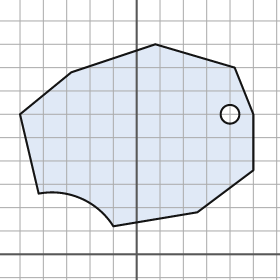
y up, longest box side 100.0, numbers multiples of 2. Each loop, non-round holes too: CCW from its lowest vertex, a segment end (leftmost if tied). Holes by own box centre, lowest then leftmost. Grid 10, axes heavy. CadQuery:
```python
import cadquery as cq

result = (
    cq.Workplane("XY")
    .moveTo(-10.0, 12.0)
    .lineTo(26.0, 18.0)
    .lineTo(50.0, 36.0)
    .lineTo(50.0, 60.0)
    .lineTo(42.0, 80.0)
    .lineTo(8.0, 90.0)
    .lineTo(-28.0, 78.0)
    .lineTo(-50.0, 60.0)
    .lineTo(-42.0, 26.0)
    .threePointArc((-24.0, 24.0), (-10.0, 12.0))
    .close()
    .moveTo(40.0, 60.0)
    .circle(4.0)
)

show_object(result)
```